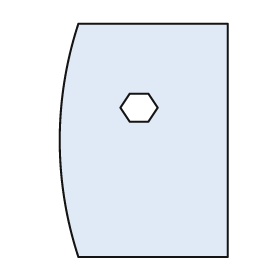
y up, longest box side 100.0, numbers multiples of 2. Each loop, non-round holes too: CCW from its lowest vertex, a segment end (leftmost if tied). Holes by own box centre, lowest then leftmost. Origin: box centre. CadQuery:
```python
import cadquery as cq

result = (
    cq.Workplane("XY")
    .moveTo(-28.0, -50.0)
    .lineTo(36.0, -50.0)
    .lineTo(36.0, 50.0)
    .lineTo(-28.0, 50.0)
    .threePointArc((-36.0, 0.0), (-28.0, -50.0))
    .close()
    .moveTo(-6.0, 8.0)
    .lineTo(2.0, 8.0)
    .lineTo(6.0, 14.0)
    .lineTo(2.0, 20.0)
    .lineTo(-6.0, 20.0)
    .lineTo(-10.0, 14.0)
    .close()
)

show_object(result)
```